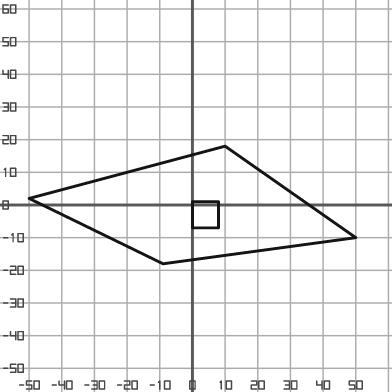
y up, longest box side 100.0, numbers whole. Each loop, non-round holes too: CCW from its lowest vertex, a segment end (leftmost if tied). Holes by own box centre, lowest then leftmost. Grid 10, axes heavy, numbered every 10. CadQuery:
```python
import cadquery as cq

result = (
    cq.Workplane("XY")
    .moveTo(-9.0, -18.0)
    .lineTo(50.0, -10.0)
    .lineTo(10.0, 18.0)
    .lineTo(-50.0, 2.0)
    .close()
    .moveTo(0.0, -7.0)
    .lineTo(8.0, -7.0)
    .lineTo(8.0, 1.0)
    .lineTo(0.0, 1.0)
    .close()
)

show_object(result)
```